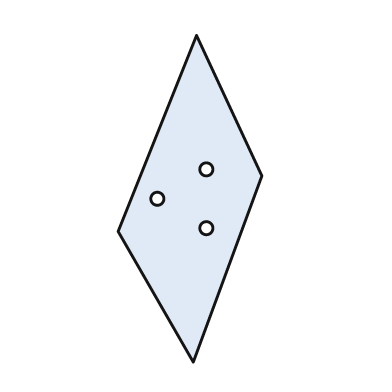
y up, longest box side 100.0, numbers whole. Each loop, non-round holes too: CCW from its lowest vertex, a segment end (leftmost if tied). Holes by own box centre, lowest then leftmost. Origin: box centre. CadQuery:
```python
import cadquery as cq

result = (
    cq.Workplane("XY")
    .moveTo(1.0, -50.0)
    .lineTo(22.0, 7.0)
    .lineTo(2.0, 50.0)
    .lineTo(-22.0, -10.0)
    .close()
    .moveTo(5.0, -9.0)
    .circle(2.0)
    .moveTo(-10.0, 0.0)
    .circle(2.0)
    .moveTo(5.0, 9.0)
    .circle(2.0)
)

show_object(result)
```